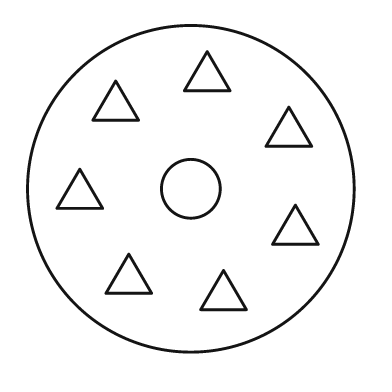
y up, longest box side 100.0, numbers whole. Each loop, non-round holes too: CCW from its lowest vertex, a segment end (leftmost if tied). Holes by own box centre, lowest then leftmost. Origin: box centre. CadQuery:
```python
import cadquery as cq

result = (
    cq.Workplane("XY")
    .moveTo(0.0, 0.0)
    .circle(50.0)
    .moveTo(3.0, -37.0)
    .lineTo(17.0, -37.0)
    .lineTo(10.0, -25.0)
    .close()
    .moveTo(-26.0, -32.0)
    .lineTo(-12.0, -32.0)
    .lineTo(-19.0, -20.0)
    .close()
    .moveTo(25.0, -17.0)
    .lineTo(39.0, -17.0)
    .lineTo(32.0, -5.0)
    .close()
    .moveTo(-41.0, -6.0)
    .lineTo(-27.0, -6.0)
    .lineTo(-34.0, 6.0)
    .close()
    .moveTo(0.0, 0.0)
    .circle(9.0)
    .moveTo(23.0, 13.0)
    .lineTo(37.0, 13.0)
    .lineTo(30.0, 25.0)
    .close()
    .moveTo(-30.0, 21.0)
    .lineTo(-16.0, 21.0)
    .lineTo(-23.0, 33.0)
    .close()
    .moveTo(-2.0, 30.0)
    .lineTo(12.0, 30.0)
    .lineTo(5.0, 42.0)
    .close()
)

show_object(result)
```